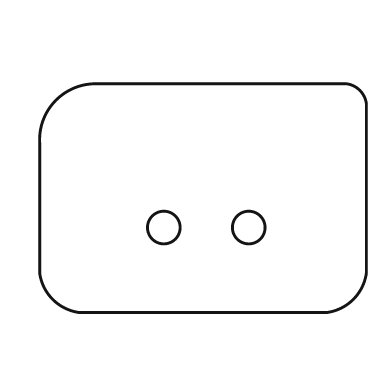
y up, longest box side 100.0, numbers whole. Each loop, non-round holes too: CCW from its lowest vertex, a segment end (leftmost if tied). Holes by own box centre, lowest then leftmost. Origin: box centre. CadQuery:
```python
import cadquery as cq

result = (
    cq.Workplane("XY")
    .moveTo(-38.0, -35.0)
    .lineTo(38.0, -35.0)
    .threePointArc((46.0, -31.0), (50.0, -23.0))
    .lineTo(50.0, 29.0)
    .threePointArc((48.0, 33.0), (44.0, 35.0))
    .lineTo(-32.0, 35.0)
    .threePointArc((-45.0, 30.0), (-50.0, 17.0))
    .lineTo(-50.0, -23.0)
    .threePointArc((-46.0, -31.0), (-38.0, -35.0))
    .close()
    .moveTo(-12.0, -9.0)
    .circle(5.0)
    .moveTo(14.0, -9.0)
    .circle(5.0)
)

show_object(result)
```